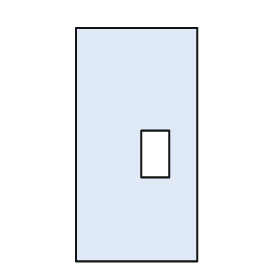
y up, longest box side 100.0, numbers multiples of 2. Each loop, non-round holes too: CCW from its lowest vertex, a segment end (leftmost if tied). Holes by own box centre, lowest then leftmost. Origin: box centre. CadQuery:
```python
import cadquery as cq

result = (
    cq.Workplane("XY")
    .moveTo(-26.0, -50.0)
    .lineTo(26.0, -50.0)
    .lineTo(26.0, 50.0)
    .lineTo(-26.0, 50.0)
    .close()
    .moveTo(2.0, -14.0)
    .lineTo(14.0, -14.0)
    .lineTo(14.0, 6.0)
    .lineTo(2.0, 6.0)
    .close()
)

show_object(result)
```